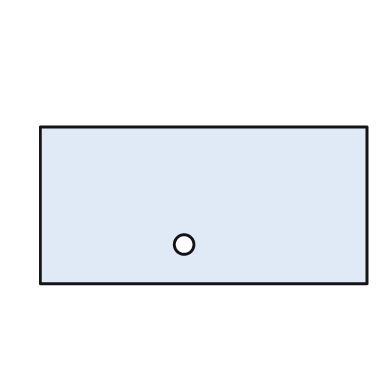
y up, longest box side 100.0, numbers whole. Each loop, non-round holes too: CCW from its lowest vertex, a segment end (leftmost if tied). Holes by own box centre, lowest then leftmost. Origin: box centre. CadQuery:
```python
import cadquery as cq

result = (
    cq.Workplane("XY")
    .moveTo(-50.0, -24.0)
    .lineTo(50.0, -24.0)
    .lineTo(50.0, 24.0)
    .lineTo(-50.0, 24.0)
    .close()
    .moveTo(-6.0, -12.0)
    .circle(3.0)
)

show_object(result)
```